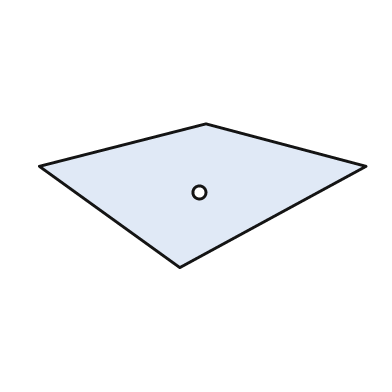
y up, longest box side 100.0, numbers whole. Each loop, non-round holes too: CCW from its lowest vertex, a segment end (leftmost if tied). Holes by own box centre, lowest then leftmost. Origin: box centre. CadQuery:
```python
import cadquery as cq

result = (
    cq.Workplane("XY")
    .moveTo(-7.0, -22.0)
    .lineTo(50.0, 9.0)
    .lineTo(1.0, 22.0)
    .lineTo(-50.0, 9.0)
    .close()
    .moveTo(-1.0, 1.0)
    .circle(2.0)
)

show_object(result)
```